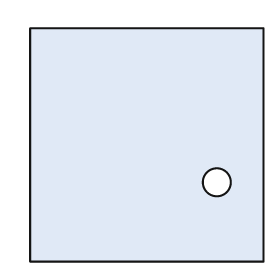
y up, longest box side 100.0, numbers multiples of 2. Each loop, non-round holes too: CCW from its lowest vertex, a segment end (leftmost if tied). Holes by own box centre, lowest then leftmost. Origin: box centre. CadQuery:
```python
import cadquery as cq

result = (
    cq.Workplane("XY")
    .moveTo(-50.0, -50.0)
    .lineTo(50.0, -50.0)
    .lineTo(50.0, 50.0)
    .lineTo(-50.0, 50.0)
    .close()
    .moveTo(30.0, -16.0)
    .circle(6.0)
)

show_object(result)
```